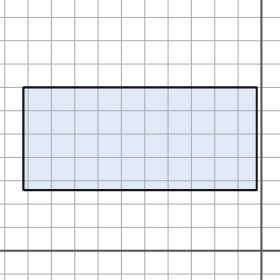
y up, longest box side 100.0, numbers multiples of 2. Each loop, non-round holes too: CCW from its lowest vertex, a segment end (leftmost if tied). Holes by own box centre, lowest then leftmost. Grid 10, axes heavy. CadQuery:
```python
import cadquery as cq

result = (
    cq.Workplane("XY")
    .moveTo(-102.0, 26.0)
    .lineTo(-2.0, 26.0)
    .lineTo(-2.0, 70.0)
    .lineTo(-102.0, 70.0)
    .close()
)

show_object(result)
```